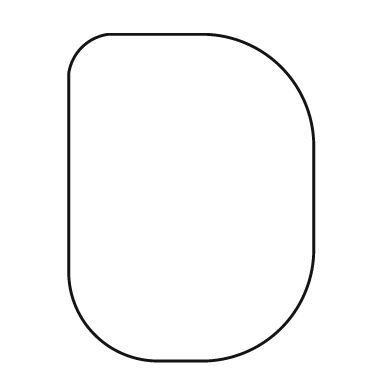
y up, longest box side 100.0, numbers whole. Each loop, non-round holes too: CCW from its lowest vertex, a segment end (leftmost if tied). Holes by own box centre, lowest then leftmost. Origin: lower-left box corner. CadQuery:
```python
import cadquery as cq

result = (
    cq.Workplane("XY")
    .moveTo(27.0, 0.0)
    .lineTo(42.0, 0.0)
    .threePointArc((65.0, 10.0), (75.0, 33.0))
    .lineTo(75.0, 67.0)
    .threePointArc((65.0, 90.0), (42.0, 100.0))
    .lineTo(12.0, 100.0)
    .threePointArc((4.0, 96.0), (0.0, 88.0))
    .lineTo(0.0, 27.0)
    .threePointArc((8.0, 8.0), (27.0, 0.0))
    .close()
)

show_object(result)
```